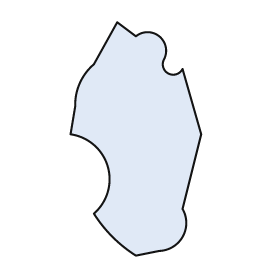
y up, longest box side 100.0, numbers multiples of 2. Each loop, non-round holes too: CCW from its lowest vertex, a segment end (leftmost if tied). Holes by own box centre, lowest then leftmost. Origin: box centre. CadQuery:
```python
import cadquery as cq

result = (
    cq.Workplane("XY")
    .moveTo(0.0, -50.0)
    .lineTo(10.0, -48.0)
    .threePointArc((20.0, -42.0), (20.0, -30.0))
    .lineTo(28.0, 2.0)
    .lineTo(20.0, 30.0)
    .threePointArc((14.0, 28.0), (12.0, 34.0))
    .threePointArc((10.0, 44.0), (0.0, 44.0))
    .lineTo(-8.0, 50.0)
    .lineTo(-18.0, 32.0)
    .threePointArc((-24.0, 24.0), (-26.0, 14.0))
    .lineTo(-28.0, 2.0)
    .threePointArc((-12.0, -12.0), (-18.0, -32.0))
    .threePointArc((-10.0, -42.0), (0.0, -50.0))
    .close()
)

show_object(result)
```